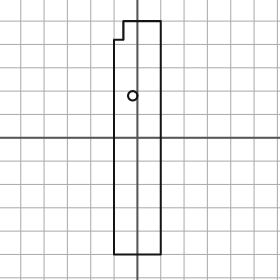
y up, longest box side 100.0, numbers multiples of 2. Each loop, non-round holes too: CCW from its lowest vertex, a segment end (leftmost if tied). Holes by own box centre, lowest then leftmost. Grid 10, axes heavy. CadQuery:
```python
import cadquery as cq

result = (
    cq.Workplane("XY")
    .moveTo(-10.0, -50.0)
    .lineTo(10.0, -50.0)
    .lineTo(10.0, 50.0)
    .lineTo(-6.0, 50.0)
    .lineTo(-6.0, 42.0)
    .lineTo(-10.0, 42.0)
    .close()
    .moveTo(-2.0, 18.0)
    .circle(2.0)
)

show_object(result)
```